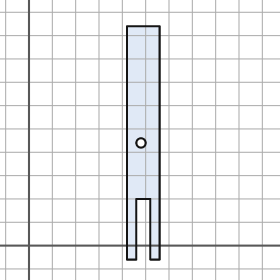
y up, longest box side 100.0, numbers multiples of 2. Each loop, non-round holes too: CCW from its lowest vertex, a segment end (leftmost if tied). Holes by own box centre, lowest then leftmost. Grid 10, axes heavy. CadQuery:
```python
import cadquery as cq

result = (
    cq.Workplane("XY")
    .moveTo(42.0, -6.0)
    .lineTo(46.0, -6.0)
    .lineTo(46.0, 20.0)
    .lineTo(52.0, 20.0)
    .lineTo(52.0, -6.0)
    .lineTo(56.0, -6.0)
    .lineTo(56.0, 94.0)
    .lineTo(42.0, 94.0)
    .close()
    .moveTo(48.0, 44.0)
    .circle(2.0)
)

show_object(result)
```